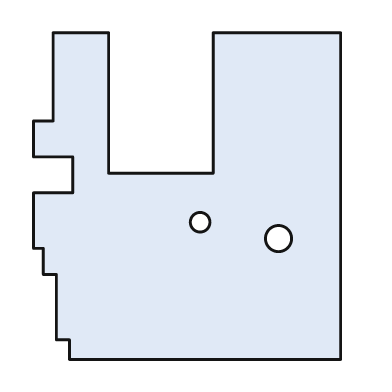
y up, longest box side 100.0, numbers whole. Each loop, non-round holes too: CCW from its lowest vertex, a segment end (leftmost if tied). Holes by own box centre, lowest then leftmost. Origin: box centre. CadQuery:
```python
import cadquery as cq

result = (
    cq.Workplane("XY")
    .moveTo(-36.0, -50.0)
    .lineTo(47.0, -50.0)
    .lineTo(47.0, 50.0)
    .lineTo(8.0, 50.0)
    .lineTo(8.0, 7.0)
    .lineTo(-24.0, 7.0)
    .lineTo(-24.0, 50.0)
    .lineTo(-41.0, 50.0)
    .lineTo(-41.0, 23.0)
    .lineTo(-47.0, 23.0)
    .lineTo(-47.0, 12.0)
    .lineTo(-35.0, 12.0)
    .lineTo(-35.0, 1.0)
    .lineTo(-47.0, 1.0)
    .lineTo(-47.0, -16.0)
    .lineTo(-44.0, -16.0)
    .lineTo(-44.0, -24.0)
    .lineTo(-40.0, -24.0)
    .lineTo(-40.0, -44.0)
    .lineTo(-36.0, -44.0)
    .close()
    .moveTo(28.0, -13.0)
    .circle(4.0)
    .moveTo(4.0, -8.0)
    .circle(3.0)
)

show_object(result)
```